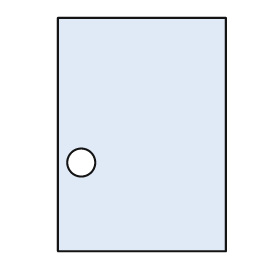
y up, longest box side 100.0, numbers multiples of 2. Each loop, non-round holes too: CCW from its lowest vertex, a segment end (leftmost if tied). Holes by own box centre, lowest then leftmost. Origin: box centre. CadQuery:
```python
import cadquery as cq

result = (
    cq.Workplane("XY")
    .moveTo(-36.0, -50.0)
    .lineTo(36.0, -50.0)
    .lineTo(36.0, 50.0)
    .lineTo(-36.0, 50.0)
    .close()
    .moveTo(-26.0, -12.0)
    .circle(6.0)
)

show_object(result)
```